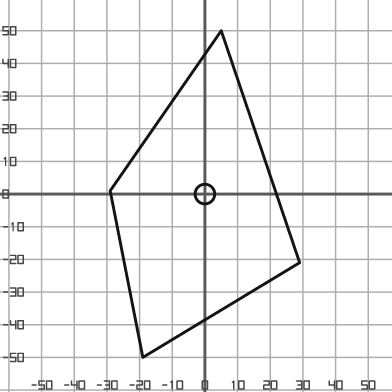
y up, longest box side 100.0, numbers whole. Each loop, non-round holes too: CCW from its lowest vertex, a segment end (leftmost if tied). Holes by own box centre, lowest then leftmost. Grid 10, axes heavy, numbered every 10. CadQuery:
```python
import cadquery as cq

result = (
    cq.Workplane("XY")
    .moveTo(-19.0, -50.0)
    .lineTo(29.0, -21.0)
    .lineTo(5.0, 50.0)
    .lineTo(-29.0, 1.0)
    .close()
    .moveTo(0.0, 0.0)
    .circle(3.0)
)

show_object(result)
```